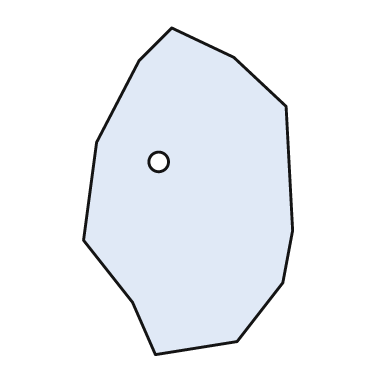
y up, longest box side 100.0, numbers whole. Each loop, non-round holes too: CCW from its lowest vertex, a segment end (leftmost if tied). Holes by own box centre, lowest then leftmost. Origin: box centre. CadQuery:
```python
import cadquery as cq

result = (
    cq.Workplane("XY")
    .moveTo(-10.0, -50.0)
    .lineTo(15.0, -46.0)
    .lineTo(29.0, -28.0)
    .lineTo(32.0, -12.0)
    .lineTo(30.0, 26.0)
    .lineTo(14.0, 41.0)
    .lineTo(-5.0, 50.0)
    .lineTo(-15.0, 40.0)
    .lineTo(-28.0, 15.0)
    .lineTo(-32.0, -15.0)
    .lineTo(-17.0, -34.0)
    .close()
    .moveTo(-9.0, 9.0)
    .circle(3.0)
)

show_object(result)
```